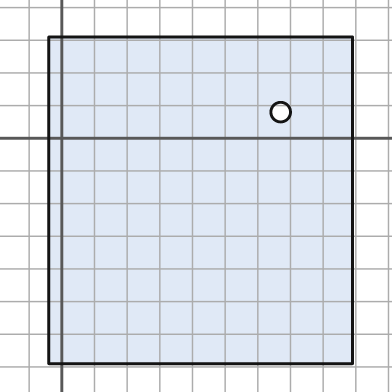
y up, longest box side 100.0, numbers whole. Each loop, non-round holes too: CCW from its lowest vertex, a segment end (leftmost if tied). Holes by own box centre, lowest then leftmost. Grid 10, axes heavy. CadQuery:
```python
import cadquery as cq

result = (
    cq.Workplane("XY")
    .moveTo(-4.0, -69.0)
    .lineTo(89.0, -69.0)
    .lineTo(89.0, 31.0)
    .lineTo(-4.0, 31.0)
    .close()
    .moveTo(67.0, 8.0)
    .circle(3.0)
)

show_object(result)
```